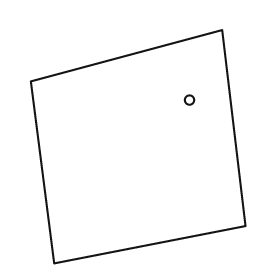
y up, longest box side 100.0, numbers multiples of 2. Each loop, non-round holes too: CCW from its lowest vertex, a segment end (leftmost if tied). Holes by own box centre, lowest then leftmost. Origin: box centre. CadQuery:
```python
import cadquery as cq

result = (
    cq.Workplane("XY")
    .moveTo(-36.0, -50.0)
    .lineTo(46.0, -34.0)
    .lineTo(36.0, 50.0)
    .lineTo(-46.0, 28.0)
    .close()
    .moveTo(22.0, 20.0)
    .circle(2.0)
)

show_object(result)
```